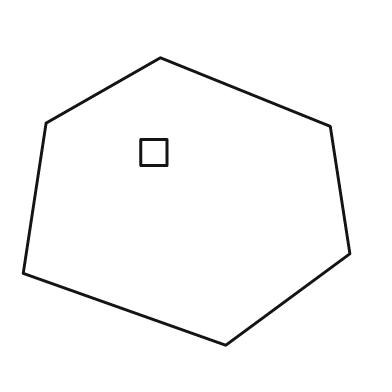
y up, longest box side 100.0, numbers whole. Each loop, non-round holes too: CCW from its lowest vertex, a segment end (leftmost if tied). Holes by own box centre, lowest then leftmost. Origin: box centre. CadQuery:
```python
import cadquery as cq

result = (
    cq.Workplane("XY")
    .moveTo(12.0, -44.0)
    .lineTo(50.0, -16.0)
    .lineTo(44.0, 23.0)
    .lineTo(-8.0, 44.0)
    .lineTo(-43.0, 24.0)
    .lineTo(-50.0, -22.0)
    .close()
    .moveTo(-14.0, 11.0)
    .lineTo(-6.0, 11.0)
    .lineTo(-6.0, 19.0)
    .lineTo(-14.0, 19.0)
    .close()
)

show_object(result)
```